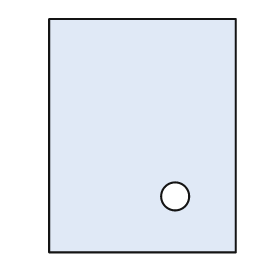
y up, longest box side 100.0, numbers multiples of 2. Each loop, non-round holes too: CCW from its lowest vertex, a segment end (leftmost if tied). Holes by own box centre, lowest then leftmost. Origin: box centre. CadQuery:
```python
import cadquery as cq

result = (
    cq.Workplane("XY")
    .moveTo(-40.0, -50.0)
    .lineTo(40.0, -50.0)
    .lineTo(40.0, 50.0)
    .lineTo(-40.0, 50.0)
    .close()
    .moveTo(14.0, -26.0)
    .circle(6.0)
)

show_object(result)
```